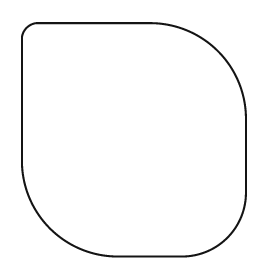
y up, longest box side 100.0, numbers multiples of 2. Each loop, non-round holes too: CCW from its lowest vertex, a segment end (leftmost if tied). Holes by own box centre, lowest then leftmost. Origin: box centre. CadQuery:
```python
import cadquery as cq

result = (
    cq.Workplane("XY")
    .moveTo(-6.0, -50.0)
    .lineTo(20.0, -50.0)
    .threePointArc((40.0, -42.0), (48.0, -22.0))
    .lineTo(48.0, 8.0)
    .threePointArc((36.0, 38.0), (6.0, 50.0))
    .lineTo(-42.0, 50.0)
    .threePointArc((-46.0, 48.0), (-48.0, 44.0))
    .lineTo(-48.0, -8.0)
    .threePointArc((-36.0, -38.0), (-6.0, -50.0))
    .close()
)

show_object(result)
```